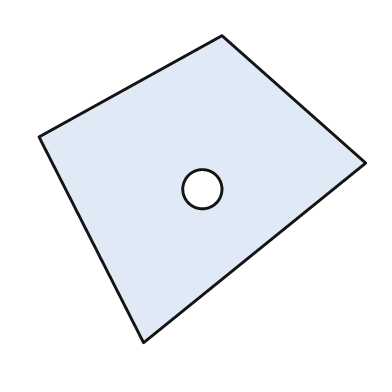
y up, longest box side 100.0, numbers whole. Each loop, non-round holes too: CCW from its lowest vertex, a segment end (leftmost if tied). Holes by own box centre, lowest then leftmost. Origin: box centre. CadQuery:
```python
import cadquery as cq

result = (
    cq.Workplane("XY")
    .moveTo(-18.0, -47.0)
    .lineTo(50.0, 8.0)
    .lineTo(6.0, 47.0)
    .lineTo(-50.0, 16.0)
    .close()
    .moveTo(0.0, 0.0)
    .circle(6.0)
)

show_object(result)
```